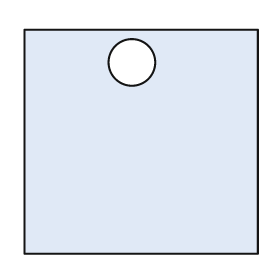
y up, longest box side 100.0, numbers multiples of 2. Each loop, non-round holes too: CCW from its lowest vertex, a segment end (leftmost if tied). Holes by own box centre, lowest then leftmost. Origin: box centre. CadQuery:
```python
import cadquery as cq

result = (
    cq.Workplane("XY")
    .moveTo(-50.0, -48.0)
    .lineTo(50.0, -48.0)
    .lineTo(50.0, 48.0)
    .lineTo(-50.0, 48.0)
    .close()
    .moveTo(-4.0, 34.0)
    .circle(10.0)
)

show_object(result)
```